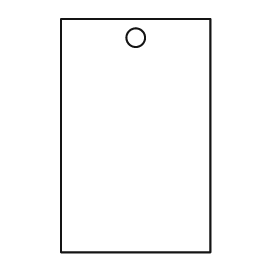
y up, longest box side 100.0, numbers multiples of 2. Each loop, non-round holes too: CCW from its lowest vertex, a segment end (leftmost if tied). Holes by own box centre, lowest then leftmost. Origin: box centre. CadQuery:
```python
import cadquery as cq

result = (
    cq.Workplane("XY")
    .moveTo(-32.0, -50.0)
    .lineTo(32.0, -50.0)
    .lineTo(32.0, 50.0)
    .lineTo(-32.0, 50.0)
    .close()
    .moveTo(0.0, 42.0)
    .circle(4.0)
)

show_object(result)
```